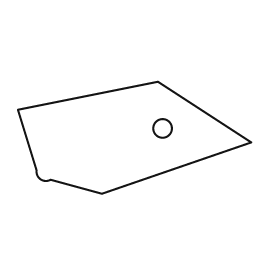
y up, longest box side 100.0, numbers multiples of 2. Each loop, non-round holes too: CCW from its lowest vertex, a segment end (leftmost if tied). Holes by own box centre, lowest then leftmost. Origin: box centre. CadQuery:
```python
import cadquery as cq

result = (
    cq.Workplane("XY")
    .moveTo(-14.0, -24.0)
    .lineTo(50.0, -2.0)
    .lineTo(10.0, 24.0)
    .lineTo(-50.0, 12.0)
    .lineTo(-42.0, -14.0)
    .threePointArc((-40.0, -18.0), (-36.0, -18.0))
    .close()
    .moveTo(12.0, 4.0)
    .circle(4.0)
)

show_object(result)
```